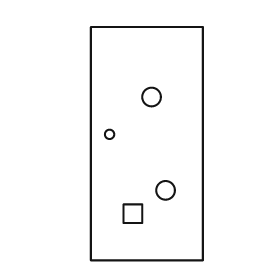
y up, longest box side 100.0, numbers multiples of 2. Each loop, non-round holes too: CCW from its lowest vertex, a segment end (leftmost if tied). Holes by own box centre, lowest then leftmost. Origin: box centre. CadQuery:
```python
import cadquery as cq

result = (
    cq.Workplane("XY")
    .moveTo(-24.0, -50.0)
    .lineTo(24.0, -50.0)
    .lineTo(24.0, 50.0)
    .lineTo(-24.0, 50.0)
    .close()
    .moveTo(-10.0, -34.0)
    .lineTo(-2.0, -34.0)
    .lineTo(-2.0, -26.0)
    .lineTo(-10.0, -26.0)
    .close()
    .moveTo(8.0, -20.0)
    .circle(4.0)
    .moveTo(-16.0, 4.0)
    .circle(2.0)
    .moveTo(2.0, 20.0)
    .circle(4.0)
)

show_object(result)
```